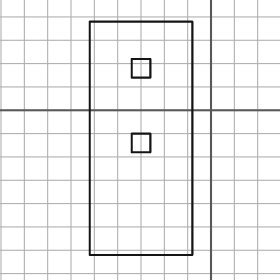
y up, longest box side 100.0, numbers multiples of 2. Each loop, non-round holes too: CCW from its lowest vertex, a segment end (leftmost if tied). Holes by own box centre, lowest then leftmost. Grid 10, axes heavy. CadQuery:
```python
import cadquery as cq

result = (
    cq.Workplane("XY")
    .moveTo(-52.0, -62.0)
    .lineTo(-8.0, -62.0)
    .lineTo(-8.0, 38.0)
    .lineTo(-52.0, 38.0)
    .close()
    .moveTo(-34.0, -18.0)
    .lineTo(-26.0, -18.0)
    .lineTo(-26.0, -10.0)
    .lineTo(-34.0, -10.0)
    .close()
    .moveTo(-34.0, 14.0)
    .lineTo(-26.0, 14.0)
    .lineTo(-26.0, 22.0)
    .lineTo(-34.0, 22.0)
    .close()
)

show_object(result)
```